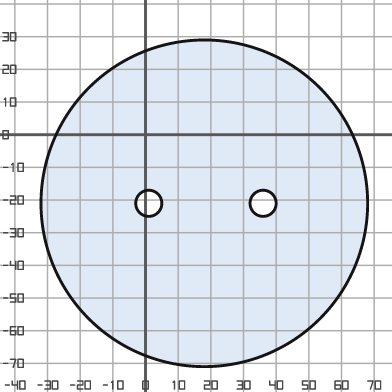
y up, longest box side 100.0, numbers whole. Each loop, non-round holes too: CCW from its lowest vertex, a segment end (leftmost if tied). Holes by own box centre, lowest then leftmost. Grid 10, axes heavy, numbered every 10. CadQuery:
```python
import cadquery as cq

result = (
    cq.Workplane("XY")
    .moveTo(18.0, -21.0)
    .circle(50.0)
    .moveTo(1.0, -21.0)
    .circle(4.0)
    .moveTo(36.0, -21.0)
    .circle(4.0)
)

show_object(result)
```